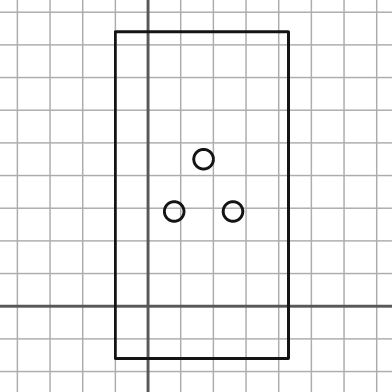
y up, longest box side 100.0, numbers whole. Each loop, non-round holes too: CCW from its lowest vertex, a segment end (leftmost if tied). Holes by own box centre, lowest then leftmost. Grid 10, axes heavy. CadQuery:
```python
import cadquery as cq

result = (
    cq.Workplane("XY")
    .moveTo(-10.0, -16.0)
    .lineTo(43.0, -16.0)
    .lineTo(43.0, 84.0)
    .lineTo(-10.0, 84.0)
    .close()
    .moveTo(8.0, 29.0)
    .circle(3.0)
    .moveTo(26.0, 29.0)
    .circle(3.0)
    .moveTo(17.0, 45.0)
    .circle(3.0)
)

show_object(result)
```